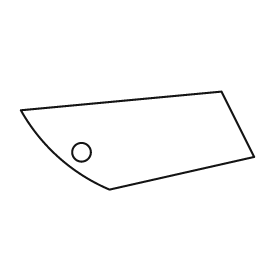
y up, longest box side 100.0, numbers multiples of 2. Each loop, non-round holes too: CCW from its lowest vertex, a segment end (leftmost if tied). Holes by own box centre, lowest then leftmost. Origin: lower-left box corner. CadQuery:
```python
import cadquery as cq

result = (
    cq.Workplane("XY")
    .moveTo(38.0, 0.0)
    .lineTo(100.0, 14.0)
    .lineTo(86.0, 42.0)
    .lineTo(0.0, 34.0)
    .threePointArc((16.0, 14.0), (38.0, 0.0))
    .close()
    .moveTo(26.0, 16.0)
    .circle(4.0)
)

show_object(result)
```